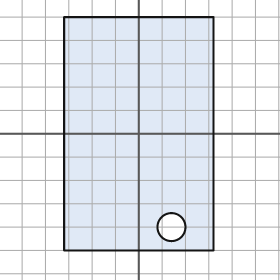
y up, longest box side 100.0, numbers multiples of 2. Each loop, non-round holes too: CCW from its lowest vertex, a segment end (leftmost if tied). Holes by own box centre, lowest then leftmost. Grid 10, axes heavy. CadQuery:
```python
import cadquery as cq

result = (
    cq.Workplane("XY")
    .moveTo(-32.0, -50.0)
    .lineTo(32.0, -50.0)
    .lineTo(32.0, 50.0)
    .lineTo(-32.0, 50.0)
    .close()
    .moveTo(14.0, -40.0)
    .circle(6.0)
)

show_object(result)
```